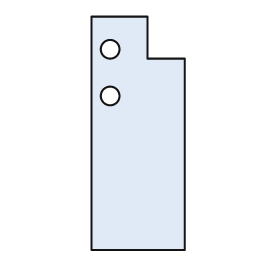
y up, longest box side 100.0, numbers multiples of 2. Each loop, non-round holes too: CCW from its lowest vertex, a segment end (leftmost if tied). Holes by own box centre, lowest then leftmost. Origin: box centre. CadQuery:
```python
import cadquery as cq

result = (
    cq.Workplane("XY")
    .moveTo(-20.0, -50.0)
    .lineTo(20.0, -50.0)
    .lineTo(20.0, 32.0)
    .lineTo(4.0, 32.0)
    .lineTo(4.0, 50.0)
    .lineTo(-20.0, 50.0)
    .close()
    .moveTo(-12.0, 16.0)
    .circle(4.0)
    .moveTo(-12.0, 36.0)
    .circle(4.0)
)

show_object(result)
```